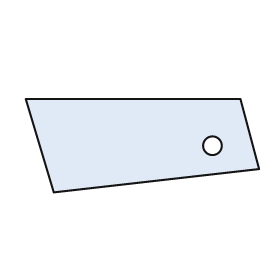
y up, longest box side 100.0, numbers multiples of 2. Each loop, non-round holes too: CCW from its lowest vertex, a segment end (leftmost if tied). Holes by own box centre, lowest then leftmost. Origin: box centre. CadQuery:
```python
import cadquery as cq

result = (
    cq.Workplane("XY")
    .moveTo(-38.0, -20.0)
    .lineTo(50.0, -10.0)
    .lineTo(42.0, 20.0)
    .lineTo(-50.0, 20.0)
    .close()
    .moveTo(30.0, 0.0)
    .circle(4.0)
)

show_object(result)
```